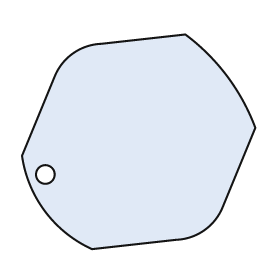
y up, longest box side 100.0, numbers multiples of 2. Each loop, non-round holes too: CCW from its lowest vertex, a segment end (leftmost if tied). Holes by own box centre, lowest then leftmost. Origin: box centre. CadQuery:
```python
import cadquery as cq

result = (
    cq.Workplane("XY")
    .moveTo(-20.0, -46.0)
    .lineTo(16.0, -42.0)
    .threePointArc((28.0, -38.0), (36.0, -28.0))
    .lineTo(50.0, 6.0)
    .threePointArc((38.0, 28.0), (20.0, 46.0))
    .lineTo(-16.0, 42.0)
    .threePointArc((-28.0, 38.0), (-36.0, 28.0))
    .lineTo(-50.0, -6.0)
    .threePointArc((-40.0, -30.0), (-20.0, -46.0))
    .close()
    .moveTo(-40.0, -14.0)
    .circle(4.0)
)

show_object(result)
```